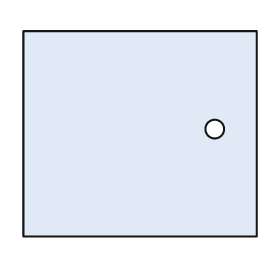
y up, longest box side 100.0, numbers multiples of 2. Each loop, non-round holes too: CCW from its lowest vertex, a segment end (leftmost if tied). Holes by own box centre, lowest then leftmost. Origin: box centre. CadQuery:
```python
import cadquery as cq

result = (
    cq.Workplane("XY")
    .moveTo(-50.0, -44.0)
    .lineTo(50.0, -44.0)
    .lineTo(50.0, 44.0)
    .lineTo(-50.0, 44.0)
    .close()
    .moveTo(32.0, 2.0)
    .circle(4.0)
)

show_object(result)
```